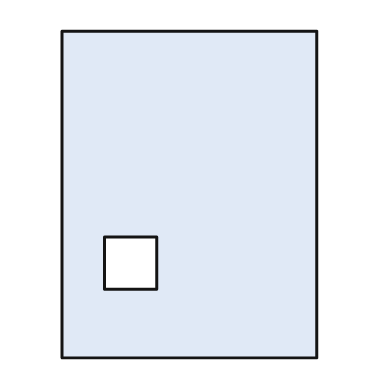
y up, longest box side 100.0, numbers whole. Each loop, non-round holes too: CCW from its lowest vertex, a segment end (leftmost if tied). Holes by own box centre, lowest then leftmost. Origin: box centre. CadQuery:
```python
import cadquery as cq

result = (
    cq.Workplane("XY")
    .moveTo(-39.0, -50.0)
    .lineTo(39.0, -50.0)
    .lineTo(39.0, 50.0)
    .lineTo(-39.0, 50.0)
    .close()
    .moveTo(-26.0, -29.0)
    .lineTo(-10.0, -29.0)
    .lineTo(-10.0, -13.0)
    .lineTo(-26.0, -13.0)
    .close()
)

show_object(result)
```